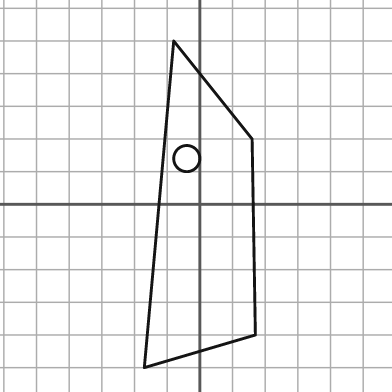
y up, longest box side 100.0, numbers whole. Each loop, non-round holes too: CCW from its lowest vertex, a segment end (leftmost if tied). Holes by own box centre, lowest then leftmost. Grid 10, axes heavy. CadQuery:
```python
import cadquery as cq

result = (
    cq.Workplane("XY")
    .moveTo(-17.0, -50.0)
    .lineTo(17.0, -40.0)
    .lineTo(16.0, 20.0)
    .lineTo(-8.0, 50.0)
    .close()
    .moveTo(-4.0, 14.0)
    .circle(4.0)
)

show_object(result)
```